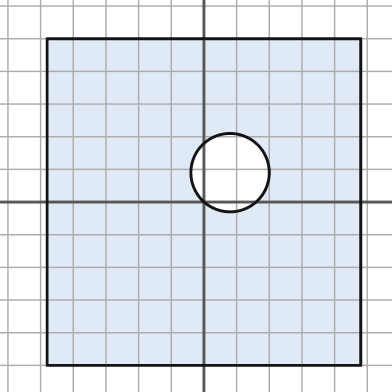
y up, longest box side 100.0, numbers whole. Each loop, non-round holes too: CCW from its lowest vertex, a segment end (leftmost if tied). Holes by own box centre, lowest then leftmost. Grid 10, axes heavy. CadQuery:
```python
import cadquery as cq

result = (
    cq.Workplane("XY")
    .moveTo(-48.0, -50.0)
    .lineTo(48.0, -50.0)
    .lineTo(48.0, 50.0)
    .lineTo(-48.0, 50.0)
    .close()
    .moveTo(8.0, 9.0)
    .circle(12.0)
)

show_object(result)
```